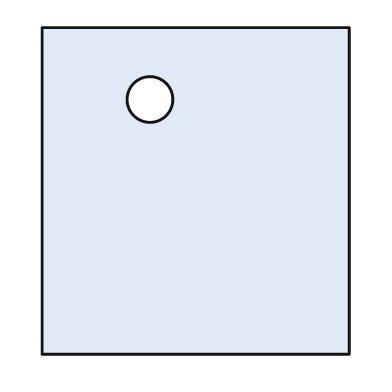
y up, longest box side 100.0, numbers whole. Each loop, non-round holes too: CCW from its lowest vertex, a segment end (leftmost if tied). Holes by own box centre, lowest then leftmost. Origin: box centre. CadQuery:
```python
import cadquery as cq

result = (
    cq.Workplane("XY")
    .moveTo(-47.0, -50.0)
    .lineTo(47.0, -50.0)
    .lineTo(47.0, 50.0)
    .lineTo(-47.0, 50.0)
    .close()
    .moveTo(-14.0, 28.0)
    .circle(7.0)
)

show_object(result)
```